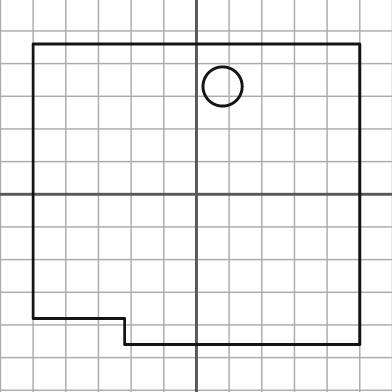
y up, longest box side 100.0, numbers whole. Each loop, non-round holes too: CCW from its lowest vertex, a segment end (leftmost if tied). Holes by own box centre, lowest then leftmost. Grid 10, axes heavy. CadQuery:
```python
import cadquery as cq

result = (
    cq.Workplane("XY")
    .moveTo(-22.0, -46.0)
    .lineTo(50.0, -46.0)
    .lineTo(50.0, 46.0)
    .lineTo(-50.0, 46.0)
    .lineTo(-50.0, -38.0)
    .lineTo(-22.0, -38.0)
    .close()
    .moveTo(8.0, 33.0)
    .circle(6.0)
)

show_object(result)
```